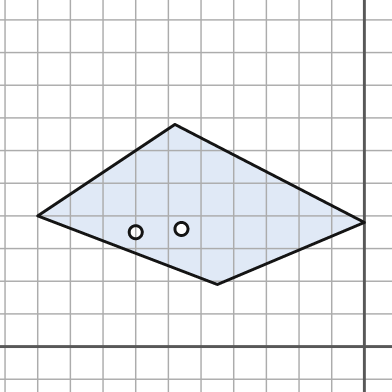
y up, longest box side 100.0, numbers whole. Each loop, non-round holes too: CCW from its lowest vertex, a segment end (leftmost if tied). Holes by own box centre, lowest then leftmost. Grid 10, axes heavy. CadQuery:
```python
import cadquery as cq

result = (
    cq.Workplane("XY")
    .moveTo(-45.0, 19.0)
    .lineTo(0.0, 38.0)
    .lineTo(-58.0, 68.0)
    .lineTo(-100.0, 40.0)
    .close()
    .moveTo(-70.0, 35.0)
    .circle(2.0)
    .moveTo(-56.0, 36.0)
    .circle(2.0)
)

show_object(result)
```